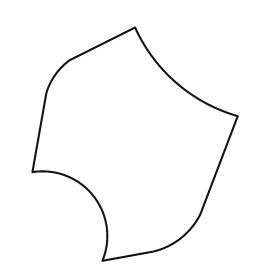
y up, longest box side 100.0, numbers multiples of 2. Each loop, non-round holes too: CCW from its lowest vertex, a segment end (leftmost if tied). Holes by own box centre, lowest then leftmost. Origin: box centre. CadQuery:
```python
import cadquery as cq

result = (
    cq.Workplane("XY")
    .moveTo(-14.0, -50.0)
    .lineTo(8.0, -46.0)
    .threePointArc((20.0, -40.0), (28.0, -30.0))
    .lineTo(44.0, 12.0)
    .threePointArc((18.0, 26.0), (0.0, 50.0))
    .lineTo(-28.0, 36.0)
    .threePointArc((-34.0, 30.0), (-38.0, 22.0))
    .lineTo(-44.0, -12.0)
    .threePointArc((-18.0, -22.0), (-14.0, -50.0))
    .close()
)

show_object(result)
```